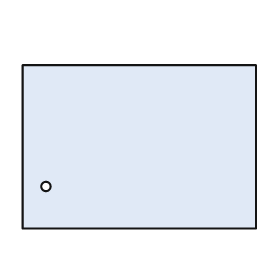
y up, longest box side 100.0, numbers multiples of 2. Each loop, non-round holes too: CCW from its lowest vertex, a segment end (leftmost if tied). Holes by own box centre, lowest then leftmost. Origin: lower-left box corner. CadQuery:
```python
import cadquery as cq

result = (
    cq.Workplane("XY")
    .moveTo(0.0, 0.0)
    .lineTo(100.0, 0.0)
    .lineTo(100.0, 70.0)
    .lineTo(0.0, 70.0)
    .close()
    .moveTo(10.0, 18.0)
    .circle(2.0)
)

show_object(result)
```